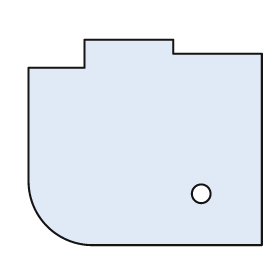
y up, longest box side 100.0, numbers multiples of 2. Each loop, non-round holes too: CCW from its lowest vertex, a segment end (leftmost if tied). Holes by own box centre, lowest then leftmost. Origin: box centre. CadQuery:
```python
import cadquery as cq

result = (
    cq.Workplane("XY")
    .moveTo(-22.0, -44.0)
    .lineTo(50.0, -44.0)
    .lineTo(50.0, 38.0)
    .lineTo(12.0, 38.0)
    .lineTo(12.0, 44.0)
    .lineTo(-26.0, 44.0)
    .lineTo(-26.0, 32.0)
    .lineTo(-50.0, 32.0)
    .lineTo(-50.0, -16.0)
    .threePointArc((-42.0, -36.0), (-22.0, -44.0))
    .close()
    .moveTo(24.0, -22.0)
    .circle(4.0)
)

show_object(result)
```